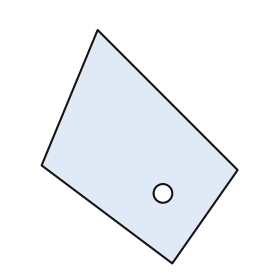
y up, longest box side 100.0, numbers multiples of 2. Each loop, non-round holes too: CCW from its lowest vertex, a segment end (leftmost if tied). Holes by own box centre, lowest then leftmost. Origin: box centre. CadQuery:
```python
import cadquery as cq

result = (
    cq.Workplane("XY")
    .moveTo(14.0, -50.0)
    .lineTo(42.0, -10.0)
    .lineTo(-18.0, 50.0)
    .lineTo(-42.0, -8.0)
    .close()
    .moveTo(10.0, -20.0)
    .circle(4.0)
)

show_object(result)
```